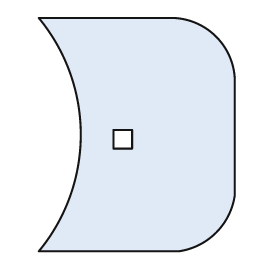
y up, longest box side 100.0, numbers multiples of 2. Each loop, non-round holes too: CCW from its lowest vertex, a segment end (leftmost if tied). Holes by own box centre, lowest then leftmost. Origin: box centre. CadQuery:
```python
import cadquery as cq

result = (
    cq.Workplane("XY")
    .moveTo(-42.0, -50.0)
    .lineTo(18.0, -50.0)
    .threePointArc((34.0, -42.0), (42.0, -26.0))
    .lineTo(42.0, 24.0)
    .threePointArc((34.0, 42.0), (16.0, 50.0))
    .lineTo(-42.0, 50.0)
    .threePointArc((-24.0, 0.0), (-42.0, -50.0))
    .close()
    .moveTo(-10.0, -6.0)
    .lineTo(-2.0, -6.0)
    .lineTo(-2.0, 2.0)
    .lineTo(-10.0, 2.0)
    .close()
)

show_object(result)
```